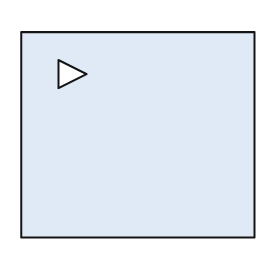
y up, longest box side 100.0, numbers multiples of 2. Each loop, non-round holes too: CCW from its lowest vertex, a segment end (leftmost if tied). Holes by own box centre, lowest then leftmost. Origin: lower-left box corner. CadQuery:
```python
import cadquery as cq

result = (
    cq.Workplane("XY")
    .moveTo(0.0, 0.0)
    .lineTo(100.0, 0.0)
    .lineTo(100.0, 88.0)
    .lineTo(0.0, 88.0)
    .close()
    .moveTo(16.0, 64.0)
    .lineTo(28.0, 70.0)
    .lineTo(16.0, 76.0)
    .close()
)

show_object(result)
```